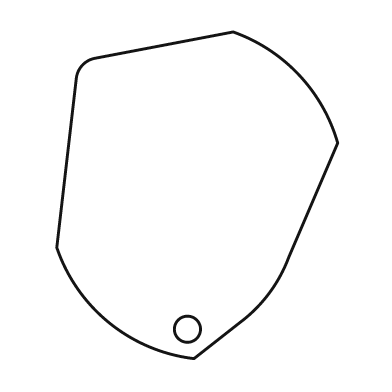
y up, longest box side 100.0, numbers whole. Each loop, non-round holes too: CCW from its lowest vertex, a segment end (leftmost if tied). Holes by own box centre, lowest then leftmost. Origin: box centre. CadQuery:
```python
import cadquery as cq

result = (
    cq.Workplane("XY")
    .moveTo(-1.0, -50.0)
    .lineTo(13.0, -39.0)
    .threePointArc((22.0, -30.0), (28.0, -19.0))
    .lineTo(43.0, 16.0)
    .threePointArc((31.0, 37.0), (11.0, 50.0))
    .lineTo(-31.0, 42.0)
    .threePointArc((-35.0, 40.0), (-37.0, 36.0))
    .lineTo(-43.0, -16.0)
    .threePointArc((-27.0, -39.0), (-1.0, -50.0))
    .close()
    .moveTo(-3.0, -41.0)
    .circle(4.0)
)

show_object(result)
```